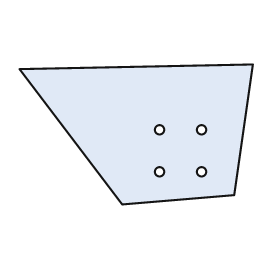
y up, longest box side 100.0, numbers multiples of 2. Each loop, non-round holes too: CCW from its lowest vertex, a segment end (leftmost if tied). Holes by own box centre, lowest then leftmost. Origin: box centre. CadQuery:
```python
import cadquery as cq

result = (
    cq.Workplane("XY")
    .moveTo(-6.0, -30.0)
    .lineTo(42.0, -26.0)
    .lineTo(50.0, 30.0)
    .lineTo(-50.0, 28.0)
    .close()
    .moveTo(10.0, -16.0)
    .circle(2.0)
    .moveTo(28.0, -16.0)
    .circle(2.0)
    .moveTo(10.0, 2.0)
    .circle(2.0)
    .moveTo(28.0, 2.0)
    .circle(2.0)
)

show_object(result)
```